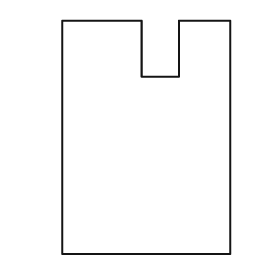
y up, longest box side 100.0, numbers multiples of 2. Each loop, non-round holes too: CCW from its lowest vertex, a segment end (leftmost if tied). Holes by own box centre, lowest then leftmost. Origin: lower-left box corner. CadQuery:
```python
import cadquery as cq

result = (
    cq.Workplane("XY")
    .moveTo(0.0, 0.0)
    .lineTo(72.0, 0.0)
    .lineTo(72.0, 100.0)
    .lineTo(50.0, 100.0)
    .lineTo(50.0, 76.0)
    .lineTo(34.0, 76.0)
    .lineTo(34.0, 100.0)
    .lineTo(0.0, 100.0)
    .close()
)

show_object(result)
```